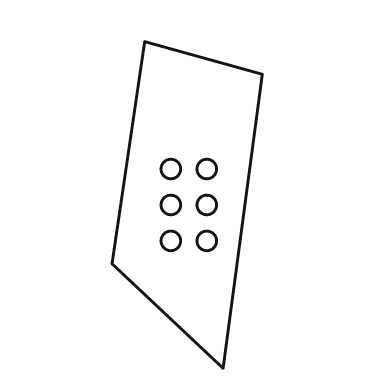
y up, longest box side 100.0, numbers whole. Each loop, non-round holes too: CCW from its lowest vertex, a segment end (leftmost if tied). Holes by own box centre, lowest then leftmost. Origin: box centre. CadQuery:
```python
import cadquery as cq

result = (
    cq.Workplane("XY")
    .moveTo(11.0, -50.0)
    .lineTo(23.0, 40.0)
    .lineTo(-13.0, 50.0)
    .lineTo(-23.0, -18.0)
    .close()
    .moveTo(-5.0, -11.0)
    .circle(3.0)
    .moveTo(6.0, -11.0)
    .circle(3.0)
    .moveTo(-5.0, 0.0)
    .circle(3.0)
    .moveTo(6.0, 0.0)
    .circle(3.0)
    .moveTo(-5.0, 11.0)
    .circle(3.0)
    .moveTo(6.0, 11.0)
    .circle(3.0)
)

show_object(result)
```